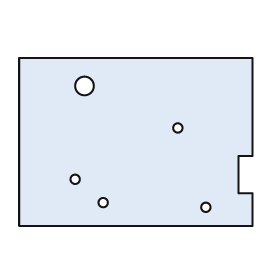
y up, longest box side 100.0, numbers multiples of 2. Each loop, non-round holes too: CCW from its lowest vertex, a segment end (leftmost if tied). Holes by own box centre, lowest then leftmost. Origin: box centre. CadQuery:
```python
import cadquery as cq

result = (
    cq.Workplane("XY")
    .moveTo(-50.0, -36.0)
    .lineTo(50.0, -36.0)
    .lineTo(50.0, -22.0)
    .lineTo(44.0, -22.0)
    .lineTo(44.0, -6.0)
    .lineTo(50.0, -6.0)
    .lineTo(50.0, 36.0)
    .lineTo(-50.0, 36.0)
    .close()
    .moveTo(30.0, -28.0)
    .circle(2.0)
    .moveTo(-14.0, -26.0)
    .circle(2.0)
    .moveTo(-26.0, -16.0)
    .circle(2.0)
    .moveTo(18.0, 6.0)
    .circle(2.0)
    .moveTo(-22.0, 24.0)
    .circle(4.0)
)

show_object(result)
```